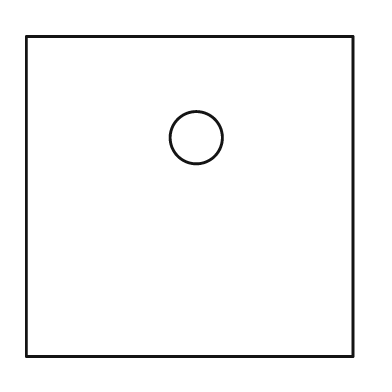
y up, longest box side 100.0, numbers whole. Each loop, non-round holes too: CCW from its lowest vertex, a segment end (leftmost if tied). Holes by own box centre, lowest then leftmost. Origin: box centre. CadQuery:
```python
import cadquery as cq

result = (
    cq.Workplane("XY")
    .moveTo(-50.0, -49.0)
    .lineTo(50.0, -49.0)
    .lineTo(50.0, 49.0)
    .lineTo(-50.0, 49.0)
    .close()
    .moveTo(2.0, 18.0)
    .circle(8.0)
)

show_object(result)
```